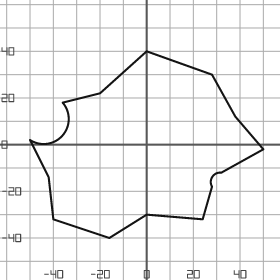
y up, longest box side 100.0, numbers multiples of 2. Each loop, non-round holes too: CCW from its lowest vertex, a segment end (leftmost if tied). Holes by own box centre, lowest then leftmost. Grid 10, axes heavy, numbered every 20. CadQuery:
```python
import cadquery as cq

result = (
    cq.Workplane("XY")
    .moveTo(-16.0, -40.0)
    .lineTo(0.0, -30.0)
    .lineTo(24.0, -32.0)
    .lineTo(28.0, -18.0)
    .threePointArc((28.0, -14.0), (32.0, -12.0))
    .lineTo(50.0, -2.0)
    .lineTo(38.0, 12.0)
    .lineTo(28.0, 30.0)
    .lineTo(0.0, 40.0)
    .lineTo(-20.0, 22.0)
    .lineTo(-36.0, 18.0)
    .threePointArc((-36.0, 4.0), (-50.0, 2.0))
    .lineTo(-42.0, -14.0)
    .lineTo(-40.0, -32.0)
    .close()
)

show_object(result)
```